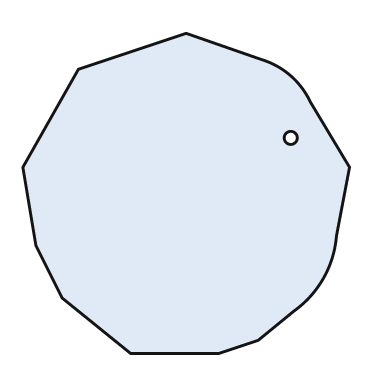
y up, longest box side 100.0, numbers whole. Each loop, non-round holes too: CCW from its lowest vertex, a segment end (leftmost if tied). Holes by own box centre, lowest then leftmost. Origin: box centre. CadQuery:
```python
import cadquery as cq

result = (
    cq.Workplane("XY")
    .moveTo(-17.0, -49.0)
    .lineTo(10.0, -49.0)
    .lineTo(22.0, -45.0)
    .lineTo(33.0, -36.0)
    .threePointArc((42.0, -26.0), (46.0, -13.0))
    .lineTo(50.0, 8.0)
    .lineTo(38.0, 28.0)
    .threePointArc((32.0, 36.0), (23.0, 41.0))
    .lineTo(0.0, 49.0)
    .lineTo(-33.0, 38.0)
    .lineTo(-50.0, 8.0)
    .lineTo(-46.0, -16.0)
    .lineTo(-38.0, -32.0)
    .close()
    .moveTo(32.0, 17.0)
    .circle(2.0)
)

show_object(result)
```